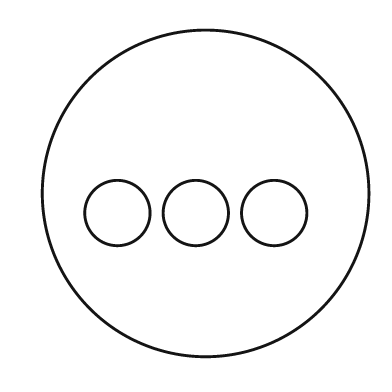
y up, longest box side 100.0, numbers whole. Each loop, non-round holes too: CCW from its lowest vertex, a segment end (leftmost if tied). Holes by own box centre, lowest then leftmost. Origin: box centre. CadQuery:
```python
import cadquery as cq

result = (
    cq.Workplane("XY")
    .moveTo(0.0, 0.0)
    .circle(50.0)
    .moveTo(-27.0, -6.0)
    .circle(10.0)
    .moveTo(-3.0, -6.0)
    .circle(10.0)
    .moveTo(21.0, -6.0)
    .circle(10.0)
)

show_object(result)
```